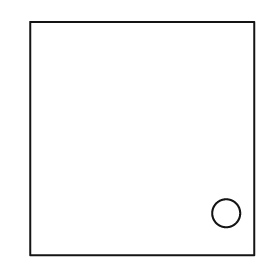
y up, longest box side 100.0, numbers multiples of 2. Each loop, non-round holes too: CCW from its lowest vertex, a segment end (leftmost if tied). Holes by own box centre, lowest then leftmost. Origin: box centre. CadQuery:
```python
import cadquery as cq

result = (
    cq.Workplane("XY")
    .moveTo(-48.0, -50.0)
    .lineTo(48.0, -50.0)
    .lineTo(48.0, 50.0)
    .lineTo(-48.0, 50.0)
    .close()
    .moveTo(36.0, -32.0)
    .circle(6.0)
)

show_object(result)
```